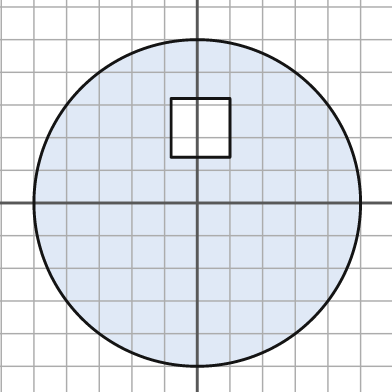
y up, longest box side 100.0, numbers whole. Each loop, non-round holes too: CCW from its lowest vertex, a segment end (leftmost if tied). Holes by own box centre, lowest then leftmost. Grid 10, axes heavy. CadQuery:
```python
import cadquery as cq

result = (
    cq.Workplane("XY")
    .moveTo(0.0, 0.0)
    .circle(50.0)
    .moveTo(-8.0, 14.0)
    .lineTo(10.0, 14.0)
    .lineTo(10.0, 32.0)
    .lineTo(-8.0, 32.0)
    .close()
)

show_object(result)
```